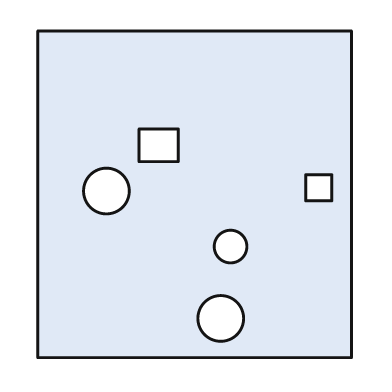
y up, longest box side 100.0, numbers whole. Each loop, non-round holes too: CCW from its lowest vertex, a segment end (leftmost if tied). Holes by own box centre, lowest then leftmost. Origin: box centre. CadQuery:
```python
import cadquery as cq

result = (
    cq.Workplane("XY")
    .moveTo(-48.0, -50.0)
    .lineTo(48.0, -50.0)
    .lineTo(48.0, 50.0)
    .lineTo(-48.0, 50.0)
    .close()
    .moveTo(8.0, -38.0)
    .circle(7.0)
    .moveTo(11.0, -16.0)
    .circle(5.0)
    .moveTo(-27.0, 1.0)
    .circle(7.0)
    .moveTo(34.0, -2.0)
    .lineTo(42.0, -2.0)
    .lineTo(42.0, 6.0)
    .lineTo(34.0, 6.0)
    .close()
    .moveTo(-17.0, 10.0)
    .lineTo(-5.0, 10.0)
    .lineTo(-5.0, 20.0)
    .lineTo(-17.0, 20.0)
    .close()
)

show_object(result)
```